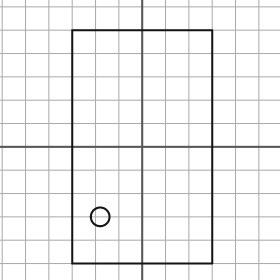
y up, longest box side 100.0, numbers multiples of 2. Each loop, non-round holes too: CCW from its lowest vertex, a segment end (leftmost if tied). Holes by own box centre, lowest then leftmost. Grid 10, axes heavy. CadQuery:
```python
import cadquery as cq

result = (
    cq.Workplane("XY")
    .moveTo(-30.0, -50.0)
    .lineTo(30.0, -50.0)
    .lineTo(30.0, 50.0)
    .lineTo(-30.0, 50.0)
    .close()
    .moveTo(-18.0, -30.0)
    .circle(4.0)
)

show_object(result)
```